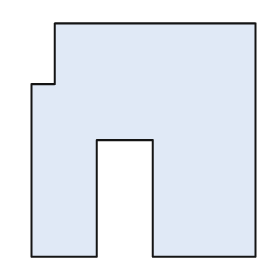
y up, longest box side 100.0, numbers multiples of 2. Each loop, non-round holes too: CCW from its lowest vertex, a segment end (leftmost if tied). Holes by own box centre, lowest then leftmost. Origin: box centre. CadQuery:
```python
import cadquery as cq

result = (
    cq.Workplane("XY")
    .moveTo(-48.0, -50.0)
    .lineTo(-20.0, -50.0)
    .lineTo(-20.0, 0.0)
    .lineTo(4.0, 0.0)
    .lineTo(4.0, -50.0)
    .lineTo(48.0, -50.0)
    .lineTo(48.0, 50.0)
    .lineTo(-38.0, 50.0)
    .lineTo(-38.0, 24.0)
    .lineTo(-48.0, 24.0)
    .close()
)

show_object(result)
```